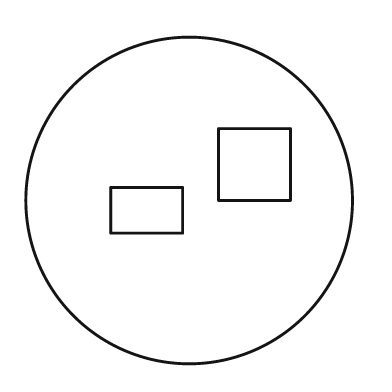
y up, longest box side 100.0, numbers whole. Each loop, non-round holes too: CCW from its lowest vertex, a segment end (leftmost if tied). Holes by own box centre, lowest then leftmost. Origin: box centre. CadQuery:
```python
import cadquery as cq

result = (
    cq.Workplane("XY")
    .moveTo(0.0, 0.0)
    .circle(50.0)
    .moveTo(-24.0, -10.0)
    .lineTo(-2.0, -10.0)
    .lineTo(-2.0, 4.0)
    .lineTo(-24.0, 4.0)
    .close()
    .moveTo(9.0, 0.0)
    .lineTo(31.0, 0.0)
    .lineTo(31.0, 22.0)
    .lineTo(9.0, 22.0)
    .close()
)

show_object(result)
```